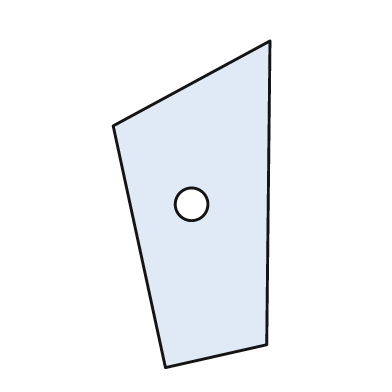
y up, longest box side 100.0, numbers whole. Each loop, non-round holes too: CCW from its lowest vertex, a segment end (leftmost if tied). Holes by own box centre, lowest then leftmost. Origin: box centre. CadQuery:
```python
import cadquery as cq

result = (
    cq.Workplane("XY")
    .moveTo(-8.0, -50.0)
    .lineTo(23.0, -43.0)
    .lineTo(24.0, 50.0)
    .lineTo(-24.0, 24.0)
    .close()
    .moveTo(0.0, 0.0)
    .circle(5.0)
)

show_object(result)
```